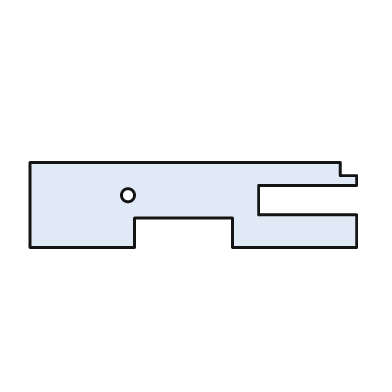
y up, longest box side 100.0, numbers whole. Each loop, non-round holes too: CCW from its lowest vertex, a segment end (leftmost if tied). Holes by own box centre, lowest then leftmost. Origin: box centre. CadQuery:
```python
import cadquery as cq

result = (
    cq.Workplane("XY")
    .moveTo(-50.0, -13.0)
    .lineTo(-18.0, -13.0)
    .lineTo(-18.0, -4.0)
    .lineTo(12.0, -4.0)
    .lineTo(12.0, -13.0)
    .lineTo(50.0, -13.0)
    .lineTo(50.0, -3.0)
    .lineTo(20.0, -3.0)
    .lineTo(20.0, 6.0)
    .lineTo(50.0, 6.0)
    .lineTo(50.0, 9.0)
    .lineTo(45.0, 9.0)
    .lineTo(45.0, 13.0)
    .lineTo(-50.0, 13.0)
    .close()
    .moveTo(-20.0, 3.0)
    .circle(2.0)
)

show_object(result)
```